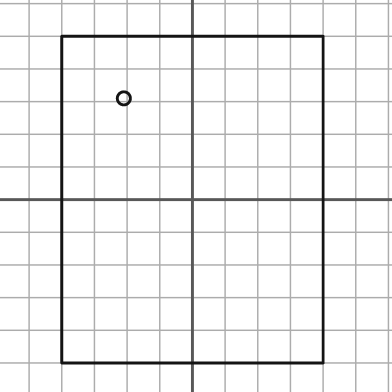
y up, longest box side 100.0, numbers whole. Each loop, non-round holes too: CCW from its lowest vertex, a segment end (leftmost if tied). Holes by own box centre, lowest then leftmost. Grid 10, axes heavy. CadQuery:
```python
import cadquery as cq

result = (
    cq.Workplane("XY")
    .moveTo(-40.0, -50.0)
    .lineTo(40.0, -50.0)
    .lineTo(40.0, 50.0)
    .lineTo(-40.0, 50.0)
    .close()
    .moveTo(-21.0, 31.0)
    .circle(2.0)
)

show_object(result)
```